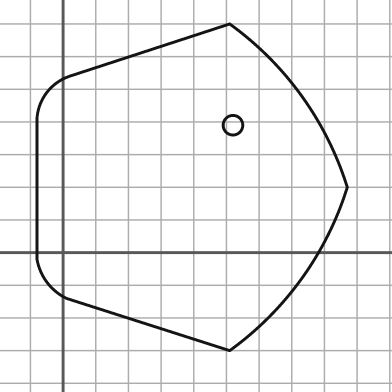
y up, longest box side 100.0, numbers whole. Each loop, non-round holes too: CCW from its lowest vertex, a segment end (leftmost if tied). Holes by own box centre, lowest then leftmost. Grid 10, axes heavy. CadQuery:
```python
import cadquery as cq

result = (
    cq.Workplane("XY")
    .moveTo(51.0, -30.0)
    .threePointArc((73.0, -8.0), (87.0, 20.0))
    .threePointArc((73.0, 48.0), (51.0, 70.0))
    .lineTo(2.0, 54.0)
    .threePointArc((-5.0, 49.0), (-8.0, 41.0))
    .lineTo(-8.0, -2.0)
    .threePointArc((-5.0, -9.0), (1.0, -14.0))
    .close()
    .moveTo(52.0, 39.0)
    .circle(3.0)
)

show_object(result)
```